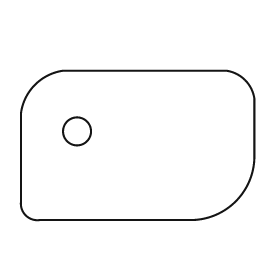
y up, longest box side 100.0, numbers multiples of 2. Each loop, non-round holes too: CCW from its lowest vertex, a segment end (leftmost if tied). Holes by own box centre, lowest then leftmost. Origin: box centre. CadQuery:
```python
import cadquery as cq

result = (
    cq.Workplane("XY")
    .moveTo(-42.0, -32.0)
    .lineTo(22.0, -32.0)
    .threePointArc((42.0, -24.0), (50.0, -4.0))
    .lineTo(50.0, 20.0)
    .threePointArc((46.0, 28.0), (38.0, 32.0))
    .lineTo(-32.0, 32.0)
    .threePointArc((-44.0, 26.0), (-50.0, 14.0))
    .lineTo(-50.0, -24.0)
    .threePointArc((-48.0, -30.0), (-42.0, -32.0))
    .close()
    .moveTo(-26.0, 6.0)
    .circle(6.0)
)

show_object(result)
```